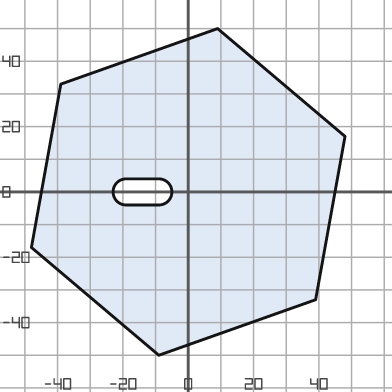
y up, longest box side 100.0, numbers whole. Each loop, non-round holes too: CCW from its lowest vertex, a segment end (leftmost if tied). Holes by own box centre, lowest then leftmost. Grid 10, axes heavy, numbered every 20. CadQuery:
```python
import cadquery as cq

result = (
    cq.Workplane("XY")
    .moveTo(-9.0, -50.0)
    .lineTo(39.0, -33.0)
    .lineTo(48.0, 17.0)
    .lineTo(9.0, 50.0)
    .lineTo(-39.0, 33.0)
    .lineTo(-48.0, -17.0)
    .close()
    .moveTo(-19.0, -4.0)
    .lineTo(-9.0, -4.0)
    .threePointArc((-5.0, 0.0), (-9.0, 4.0))
    .lineTo(-19.0, 4.0)
    .threePointArc((-23.0, 0.0), (-19.0, -4.0))
    .close()
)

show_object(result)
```